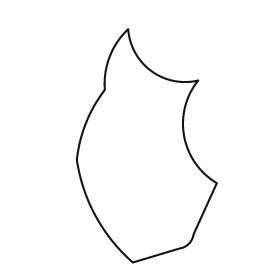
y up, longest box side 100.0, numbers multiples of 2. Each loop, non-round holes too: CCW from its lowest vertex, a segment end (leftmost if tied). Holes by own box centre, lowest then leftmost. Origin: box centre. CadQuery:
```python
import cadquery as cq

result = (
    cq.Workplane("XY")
    .moveTo(-6.0, -50.0)
    .lineTo(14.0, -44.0)
    .threePointArc((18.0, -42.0), (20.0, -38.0))
    .lineTo(30.0, -16.0)
    .threePointArc((16.0, 4.0), (22.0, 28.0))
    .threePointArc((2.0, 32.0), (-8.0, 50.0))
    .threePointArc((-16.0, 38.0), (-18.0, 24.0))
    .threePointArc((-26.0, 10.0), (-30.0, -6.0))
    .threePointArc((-22.0, -30.0), (-6.0, -50.0))
    .close()
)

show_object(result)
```